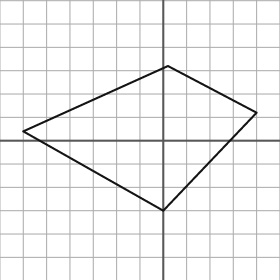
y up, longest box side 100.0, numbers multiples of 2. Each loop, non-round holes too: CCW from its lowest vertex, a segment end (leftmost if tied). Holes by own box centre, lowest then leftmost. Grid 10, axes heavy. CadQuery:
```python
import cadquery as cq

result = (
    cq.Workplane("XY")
    .moveTo(0.0, -30.0)
    .lineTo(40.0, 12.0)
    .lineTo(2.0, 32.0)
    .lineTo(-60.0, 4.0)
    .close()
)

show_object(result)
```